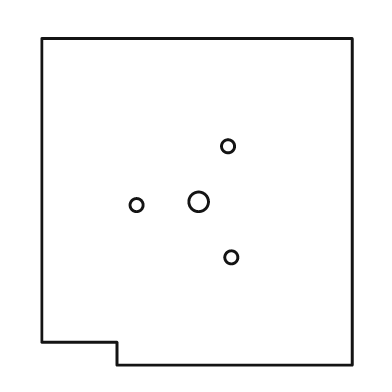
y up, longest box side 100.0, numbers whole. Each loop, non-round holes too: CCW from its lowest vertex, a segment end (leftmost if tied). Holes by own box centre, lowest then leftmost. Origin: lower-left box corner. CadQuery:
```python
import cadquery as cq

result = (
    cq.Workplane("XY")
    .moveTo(23.0, 0.0)
    .lineTo(95.0, 0.0)
    .lineTo(95.0, 100.0)
    .lineTo(0.0, 100.0)
    .lineTo(0.0, 7.0)
    .lineTo(23.0, 7.0)
    .close()
    .moveTo(58.0, 33.0)
    .circle(2.0)
    .moveTo(29.0, 49.0)
    .circle(2.0)
    .moveTo(48.0, 50.0)
    .circle(3.0)
    .moveTo(57.0, 67.0)
    .circle(2.0)
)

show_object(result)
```